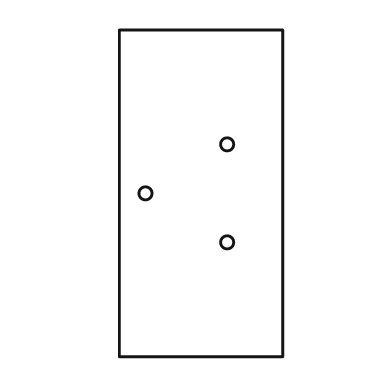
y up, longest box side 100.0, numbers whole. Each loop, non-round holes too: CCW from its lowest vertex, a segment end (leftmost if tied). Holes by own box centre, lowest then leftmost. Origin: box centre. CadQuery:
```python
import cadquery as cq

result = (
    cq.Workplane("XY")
    .moveTo(-25.0, -50.0)
    .lineTo(25.0, -50.0)
    .lineTo(25.0, 50.0)
    .lineTo(-25.0, 50.0)
    .close()
    .moveTo(8.0, -15.0)
    .circle(2.0)
    .moveTo(-17.0, 0.0)
    .circle(2.0)
    .moveTo(8.0, 15.0)
    .circle(2.0)
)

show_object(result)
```